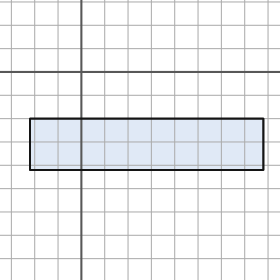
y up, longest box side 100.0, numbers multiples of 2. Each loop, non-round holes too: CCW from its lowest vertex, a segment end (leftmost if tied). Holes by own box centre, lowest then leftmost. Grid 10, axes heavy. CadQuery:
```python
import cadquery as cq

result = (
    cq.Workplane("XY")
    .moveTo(-22.0, -42.0)
    .lineTo(78.0, -42.0)
    .lineTo(78.0, -20.0)
    .lineTo(-22.0, -20.0)
    .close()
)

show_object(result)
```